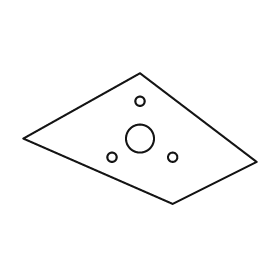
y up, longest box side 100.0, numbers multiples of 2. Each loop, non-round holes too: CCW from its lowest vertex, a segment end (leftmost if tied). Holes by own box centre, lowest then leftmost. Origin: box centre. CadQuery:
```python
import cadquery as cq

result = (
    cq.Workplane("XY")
    .moveTo(14.0, -28.0)
    .lineTo(50.0, -10.0)
    .lineTo(0.0, 28.0)
    .lineTo(-50.0, 0.0)
    .close()
    .moveTo(-12.0, -8.0)
    .circle(2.0)
    .moveTo(14.0, -8.0)
    .circle(2.0)
    .moveTo(0.0, 0.0)
    .circle(6.0)
    .moveTo(0.0, 16.0)
    .circle(2.0)
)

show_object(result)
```